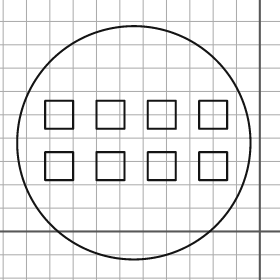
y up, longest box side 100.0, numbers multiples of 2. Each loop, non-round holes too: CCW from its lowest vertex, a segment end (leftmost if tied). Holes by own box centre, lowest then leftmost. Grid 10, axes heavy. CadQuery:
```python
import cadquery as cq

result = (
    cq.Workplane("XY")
    .moveTo(-54.0, 38.0)
    .circle(50.0)
    .moveTo(-92.0, 22.0)
    .lineTo(-80.0, 22.0)
    .lineTo(-80.0, 34.0)
    .lineTo(-92.0, 34.0)
    .close()
    .moveTo(-70.0, 22.0)
    .lineTo(-58.0, 22.0)
    .lineTo(-58.0, 34.0)
    .lineTo(-70.0, 34.0)
    .close()
    .moveTo(-48.0, 22.0)
    .lineTo(-36.0, 22.0)
    .lineTo(-36.0, 34.0)
    .lineTo(-48.0, 34.0)
    .close()
    .moveTo(-26.0, 22.0)
    .lineTo(-14.0, 22.0)
    .lineTo(-14.0, 34.0)
    .lineTo(-26.0, 34.0)
    .close()
    .moveTo(-92.0, 44.0)
    .lineTo(-80.0, 44.0)
    .lineTo(-80.0, 56.0)
    .lineTo(-92.0, 56.0)
    .close()
    .moveTo(-70.0, 44.0)
    .lineTo(-58.0, 44.0)
    .lineTo(-58.0, 56.0)
    .lineTo(-70.0, 56.0)
    .close()
    .moveTo(-48.0, 44.0)
    .lineTo(-36.0, 44.0)
    .lineTo(-36.0, 56.0)
    .lineTo(-48.0, 56.0)
    .close()
    .moveTo(-26.0, 44.0)
    .lineTo(-14.0, 44.0)
    .lineTo(-14.0, 56.0)
    .lineTo(-26.0, 56.0)
    .close()
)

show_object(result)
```